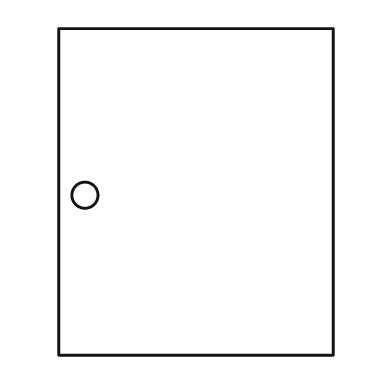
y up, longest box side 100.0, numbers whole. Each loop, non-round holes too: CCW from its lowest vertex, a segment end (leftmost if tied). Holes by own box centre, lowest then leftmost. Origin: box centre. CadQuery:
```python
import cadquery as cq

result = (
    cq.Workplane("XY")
    .moveTo(-42.0, -50.0)
    .lineTo(42.0, -50.0)
    .lineTo(42.0, 50.0)
    .lineTo(-42.0, 50.0)
    .close()
    .moveTo(-34.0, -1.0)
    .circle(4.0)
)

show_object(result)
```